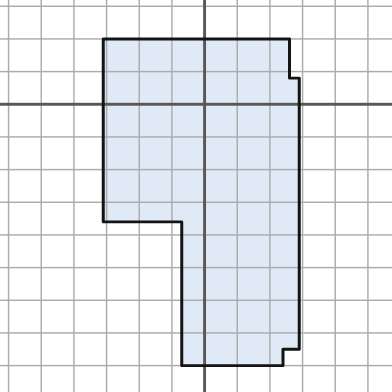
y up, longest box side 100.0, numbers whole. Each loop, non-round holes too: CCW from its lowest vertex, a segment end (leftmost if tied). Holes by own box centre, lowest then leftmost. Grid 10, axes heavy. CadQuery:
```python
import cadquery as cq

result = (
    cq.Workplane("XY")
    .moveTo(-7.0, -80.0)
    .lineTo(24.0, -80.0)
    .lineTo(24.0, -75.0)
    .lineTo(29.0, -75.0)
    .lineTo(29.0, 8.0)
    .lineTo(26.0, 8.0)
    .lineTo(26.0, 20.0)
    .lineTo(-31.0, 20.0)
    .lineTo(-31.0, -36.0)
    .lineTo(-7.0, -36.0)
    .close()
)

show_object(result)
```